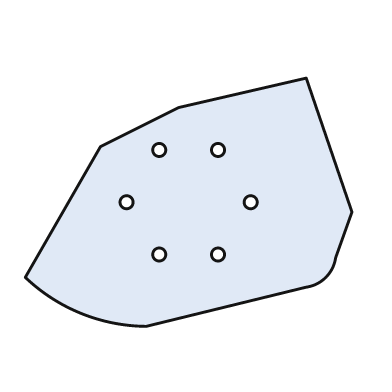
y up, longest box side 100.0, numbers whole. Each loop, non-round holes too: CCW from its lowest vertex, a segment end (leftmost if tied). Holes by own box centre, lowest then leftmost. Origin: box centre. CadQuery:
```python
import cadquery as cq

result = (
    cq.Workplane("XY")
    .moveTo(-13.0, -38.0)
    .lineTo(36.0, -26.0)
    .threePointArc((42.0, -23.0), (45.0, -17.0))
    .lineTo(50.0, -3.0)
    .lineTo(36.0, 38.0)
    .lineTo(-3.0, 29.0)
    .lineTo(-27.0, 17.0)
    .lineTo(-50.0, -23.0)
    .threePointArc((-33.0, -34.0), (-13.0, -38.0))
    .close()
    .moveTo(-9.0, -16.0)
    .circle(2.0)
    .moveTo(9.0, -16.0)
    .circle(2.0)
    .moveTo(-19.0, 0.0)
    .circle(2.0)
    .moveTo(19.0, 0.0)
    .circle(2.0)
    .moveTo(-9.0, 16.0)
    .circle(2.0)
    .moveTo(9.0, 16.0)
    .circle(2.0)
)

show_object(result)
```